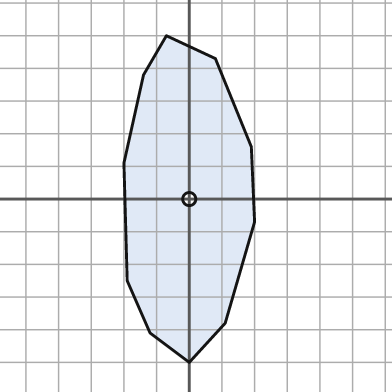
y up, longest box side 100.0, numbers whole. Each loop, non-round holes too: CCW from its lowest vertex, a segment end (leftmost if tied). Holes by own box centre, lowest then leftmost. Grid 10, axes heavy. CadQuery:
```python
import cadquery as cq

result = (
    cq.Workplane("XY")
    .moveTo(0.0, -50.0)
    .lineTo(11.0, -38.0)
    .lineTo(20.0, -7.0)
    .lineTo(19.0, 16.0)
    .lineTo(8.0, 43.0)
    .lineTo(-7.0, 50.0)
    .lineTo(-14.0, 38.0)
    .lineTo(-20.0, 11.0)
    .lineTo(-19.0, -25.0)
    .lineTo(-12.0, -41.0)
    .close()
    .moveTo(0.0, 0.0)
    .circle(2.0)
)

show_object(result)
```